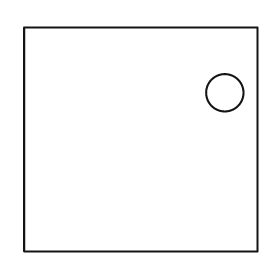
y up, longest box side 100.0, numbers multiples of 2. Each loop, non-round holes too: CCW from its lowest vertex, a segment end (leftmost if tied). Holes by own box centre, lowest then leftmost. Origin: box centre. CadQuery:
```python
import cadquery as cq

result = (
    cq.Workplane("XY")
    .moveTo(-50.0, -48.0)
    .lineTo(50.0, -48.0)
    .lineTo(50.0, 48.0)
    .lineTo(-50.0, 48.0)
    .close()
    .moveTo(36.0, 20.0)
    .circle(8.0)
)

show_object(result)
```